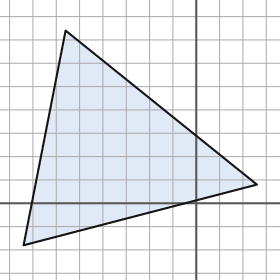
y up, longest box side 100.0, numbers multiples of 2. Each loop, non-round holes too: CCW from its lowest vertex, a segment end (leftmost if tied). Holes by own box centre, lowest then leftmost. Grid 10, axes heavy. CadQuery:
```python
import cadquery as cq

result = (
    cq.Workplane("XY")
    .moveTo(-74.0, -18.0)
    .lineTo(26.0, 8.0)
    .lineTo(-56.0, 74.0)
    .close()
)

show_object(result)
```